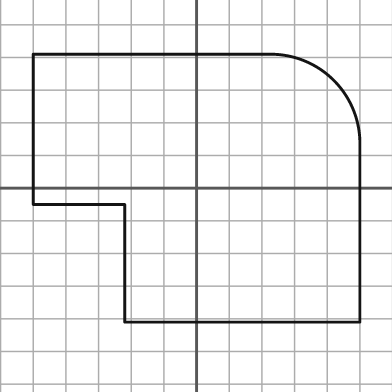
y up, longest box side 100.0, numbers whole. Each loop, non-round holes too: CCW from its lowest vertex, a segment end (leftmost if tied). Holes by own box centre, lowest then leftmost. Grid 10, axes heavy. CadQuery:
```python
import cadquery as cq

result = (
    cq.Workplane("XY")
    .moveTo(-22.0, -41.0)
    .lineTo(50.0, -41.0)
    .lineTo(50.0, 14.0)
    .threePointArc((42.0, 33.0), (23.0, 41.0))
    .lineTo(-50.0, 41.0)
    .lineTo(-50.0, -5.0)
    .lineTo(-22.0, -5.0)
    .close()
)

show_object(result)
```